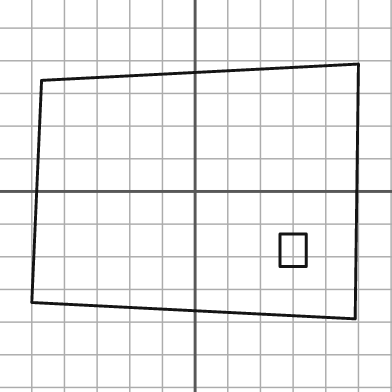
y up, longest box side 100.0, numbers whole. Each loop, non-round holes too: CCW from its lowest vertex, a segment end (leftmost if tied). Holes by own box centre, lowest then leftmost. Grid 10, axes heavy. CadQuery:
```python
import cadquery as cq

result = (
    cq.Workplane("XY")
    .moveTo(49.0, -39.0)
    .lineTo(50.0, 39.0)
    .lineTo(-47.0, 34.0)
    .lineTo(-50.0, -34.0)
    .close()
    .moveTo(26.0, -23.0)
    .lineTo(34.0, -23.0)
    .lineTo(34.0, -13.0)
    .lineTo(26.0, -13.0)
    .close()
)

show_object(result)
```